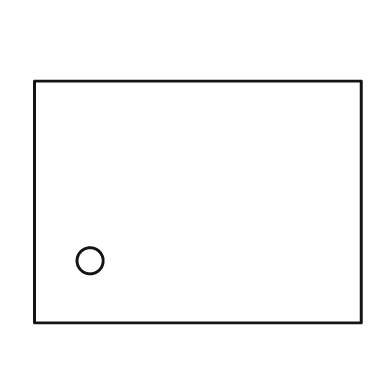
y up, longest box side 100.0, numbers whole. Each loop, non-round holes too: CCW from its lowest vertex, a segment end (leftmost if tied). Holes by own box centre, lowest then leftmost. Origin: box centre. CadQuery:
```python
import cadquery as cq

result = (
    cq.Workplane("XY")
    .moveTo(-50.0, -37.0)
    .lineTo(50.0, -37.0)
    .lineTo(50.0, 37.0)
    .lineTo(-50.0, 37.0)
    .close()
    .moveTo(-33.0, -18.0)
    .circle(4.0)
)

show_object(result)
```